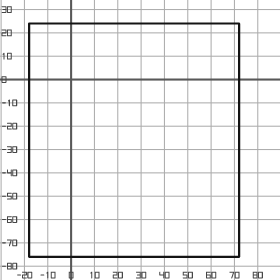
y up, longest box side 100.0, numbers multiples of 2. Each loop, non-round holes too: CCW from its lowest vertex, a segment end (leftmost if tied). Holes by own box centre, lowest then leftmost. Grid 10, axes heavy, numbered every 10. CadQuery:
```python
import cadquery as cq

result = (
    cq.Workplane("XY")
    .moveTo(-18.0, -76.0)
    .lineTo(72.0, -76.0)
    .lineTo(72.0, 24.0)
    .lineTo(-18.0, 24.0)
    .close()
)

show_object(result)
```